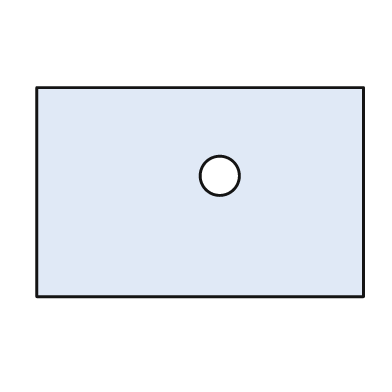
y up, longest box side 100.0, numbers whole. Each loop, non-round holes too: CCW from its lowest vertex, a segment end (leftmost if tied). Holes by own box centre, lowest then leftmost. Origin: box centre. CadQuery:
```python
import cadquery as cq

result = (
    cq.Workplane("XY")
    .moveTo(-50.0, -32.0)
    .lineTo(50.0, -32.0)
    .lineTo(50.0, 32.0)
    .lineTo(-50.0, 32.0)
    .close()
    .moveTo(6.0, 5.0)
    .circle(6.0)
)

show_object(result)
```